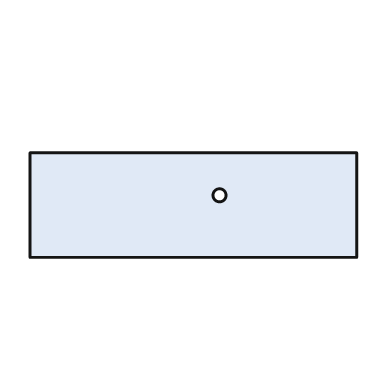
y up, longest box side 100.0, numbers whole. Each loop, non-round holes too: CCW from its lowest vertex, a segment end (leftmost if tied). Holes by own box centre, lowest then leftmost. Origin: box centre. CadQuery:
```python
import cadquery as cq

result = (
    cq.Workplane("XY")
    .moveTo(-50.0, -16.0)
    .lineTo(50.0, -16.0)
    .lineTo(50.0, 16.0)
    .lineTo(-50.0, 16.0)
    .close()
    .moveTo(8.0, 3.0)
    .circle(2.0)
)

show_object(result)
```